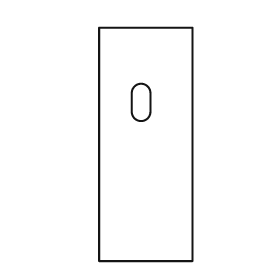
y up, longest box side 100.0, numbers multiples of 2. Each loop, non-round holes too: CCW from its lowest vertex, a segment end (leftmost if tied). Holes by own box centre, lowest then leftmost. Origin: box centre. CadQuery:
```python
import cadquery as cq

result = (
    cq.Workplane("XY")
    .moveTo(-20.0, -50.0)
    .lineTo(20.0, -50.0)
    .lineTo(20.0, 50.0)
    .lineTo(-20.0, 50.0)
    .close()
    .moveTo(-6.0, 14.0)
    .threePointArc((-2.0, 10.0), (2.0, 14.0))
    .lineTo(2.0, 22.0)
    .threePointArc((-2.0, 26.0), (-6.0, 22.0))
    .close()
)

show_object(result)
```